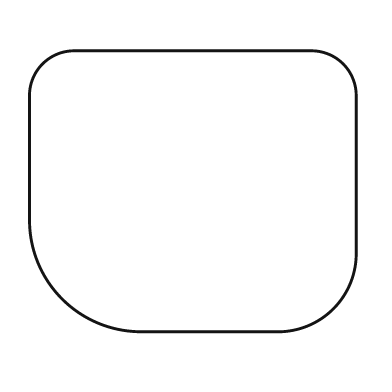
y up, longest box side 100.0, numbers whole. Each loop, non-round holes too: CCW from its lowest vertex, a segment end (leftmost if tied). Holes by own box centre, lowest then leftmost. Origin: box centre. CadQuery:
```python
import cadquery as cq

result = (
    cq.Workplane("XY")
    .moveTo(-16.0, -43.0)
    .lineTo(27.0, -43.0)
    .threePointArc((43.0, -36.0), (50.0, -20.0))
    .lineTo(50.0, 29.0)
    .threePointArc((46.0, 39.0), (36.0, 43.0))
    .lineTo(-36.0, 43.0)
    .threePointArc((-46.0, 39.0), (-50.0, 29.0))
    .lineTo(-50.0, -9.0)
    .threePointArc((-40.0, -33.0), (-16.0, -43.0))
    .close()
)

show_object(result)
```